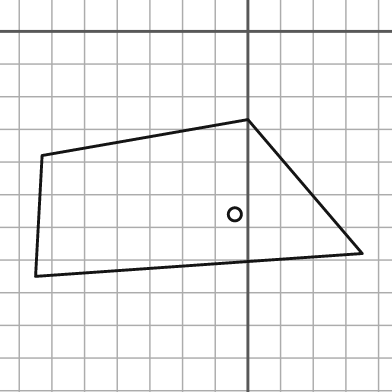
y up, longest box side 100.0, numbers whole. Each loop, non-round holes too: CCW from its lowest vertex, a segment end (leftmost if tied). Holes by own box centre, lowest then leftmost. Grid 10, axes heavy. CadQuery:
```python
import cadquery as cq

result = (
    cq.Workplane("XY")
    .moveTo(-65.0, -75.0)
    .lineTo(35.0, -68.0)
    .lineTo(0.0, -27.0)
    .lineTo(-63.0, -38.0)
    .close()
    .moveTo(-4.0, -56.0)
    .circle(2.0)
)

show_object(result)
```